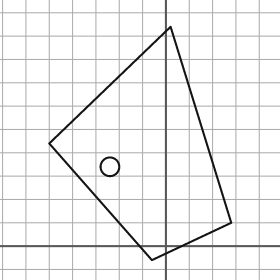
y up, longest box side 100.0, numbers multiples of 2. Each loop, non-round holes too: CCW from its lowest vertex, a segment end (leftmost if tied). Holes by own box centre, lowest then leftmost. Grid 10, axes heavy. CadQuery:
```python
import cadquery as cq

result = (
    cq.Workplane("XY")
    .moveTo(-6.0, -6.0)
    .lineTo(28.0, 10.0)
    .lineTo(2.0, 94.0)
    .lineTo(-50.0, 44.0)
    .close()
    .moveTo(-24.0, 34.0)
    .circle(4.0)
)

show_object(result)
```